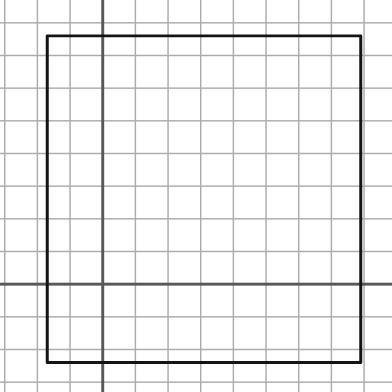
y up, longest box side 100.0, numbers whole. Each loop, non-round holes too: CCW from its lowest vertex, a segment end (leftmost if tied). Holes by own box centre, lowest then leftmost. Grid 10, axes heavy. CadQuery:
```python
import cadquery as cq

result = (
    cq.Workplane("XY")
    .moveTo(-17.0, -24.0)
    .lineTo(79.0, -24.0)
    .lineTo(79.0, 76.0)
    .lineTo(-17.0, 76.0)
    .close()
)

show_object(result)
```